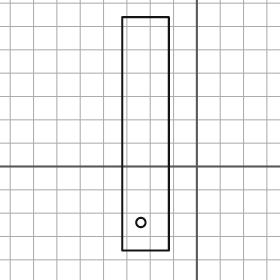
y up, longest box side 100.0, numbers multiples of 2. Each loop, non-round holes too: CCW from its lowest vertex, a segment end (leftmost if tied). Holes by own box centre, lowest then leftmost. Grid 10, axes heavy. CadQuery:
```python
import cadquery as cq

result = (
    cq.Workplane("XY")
    .moveTo(-32.0, -36.0)
    .lineTo(-12.0, -36.0)
    .lineTo(-12.0, 64.0)
    .lineTo(-32.0, 64.0)
    .close()
    .moveTo(-24.0, -24.0)
    .circle(2.0)
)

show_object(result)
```